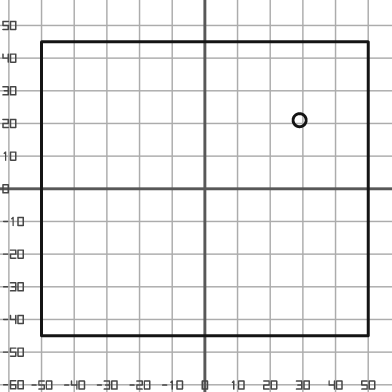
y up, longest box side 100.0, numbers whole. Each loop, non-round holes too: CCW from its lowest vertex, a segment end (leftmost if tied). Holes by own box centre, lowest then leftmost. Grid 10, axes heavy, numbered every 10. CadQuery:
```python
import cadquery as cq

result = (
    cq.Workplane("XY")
    .moveTo(-50.0, -45.0)
    .lineTo(50.0, -45.0)
    .lineTo(50.0, 45.0)
    .lineTo(-50.0, 45.0)
    .close()
    .moveTo(29.0, 21.0)
    .circle(2.0)
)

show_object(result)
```